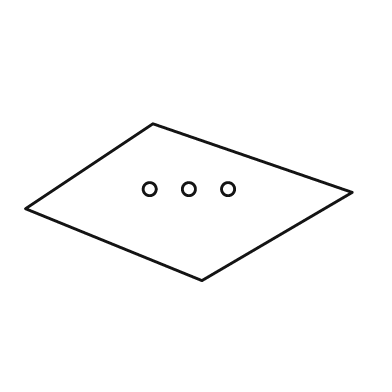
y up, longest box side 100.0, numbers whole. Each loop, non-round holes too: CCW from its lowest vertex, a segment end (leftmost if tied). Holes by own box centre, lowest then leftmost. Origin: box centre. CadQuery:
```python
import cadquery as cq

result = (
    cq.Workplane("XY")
    .moveTo(4.0, -24.0)
    .lineTo(50.0, 3.0)
    .lineTo(-11.0, 24.0)
    .lineTo(-50.0, -2.0)
    .close()
    .moveTo(-12.0, 4.0)
    .circle(2.0)
    .moveTo(0.0, 4.0)
    .circle(2.0)
    .moveTo(12.0, 4.0)
    .circle(2.0)
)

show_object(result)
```